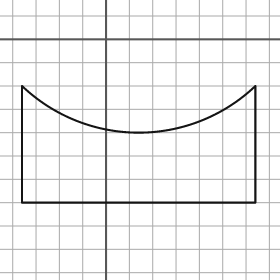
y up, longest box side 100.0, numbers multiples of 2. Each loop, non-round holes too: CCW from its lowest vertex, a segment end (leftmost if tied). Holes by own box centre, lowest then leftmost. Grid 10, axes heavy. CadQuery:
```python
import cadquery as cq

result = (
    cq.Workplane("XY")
    .moveTo(-36.0, -70.0)
    .lineTo(64.0, -70.0)
    .lineTo(64.0, -20.0)
    .threePointArc((14.0, -40.0), (-36.0, -20.0))
    .close()
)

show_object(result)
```